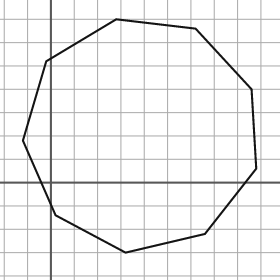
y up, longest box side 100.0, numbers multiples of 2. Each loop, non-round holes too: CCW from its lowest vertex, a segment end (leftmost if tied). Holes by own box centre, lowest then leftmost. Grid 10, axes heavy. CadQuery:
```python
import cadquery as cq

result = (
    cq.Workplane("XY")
    .moveTo(32.0, -30.0)
    .lineTo(66.0, -22.0)
    .lineTo(88.0, 6.0)
    .lineTo(86.0, 40.0)
    .lineTo(62.0, 66.0)
    .lineTo(28.0, 70.0)
    .lineTo(-2.0, 52.0)
    .lineTo(-12.0, 18.0)
    .lineTo(2.0, -14.0)
    .close()
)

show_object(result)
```